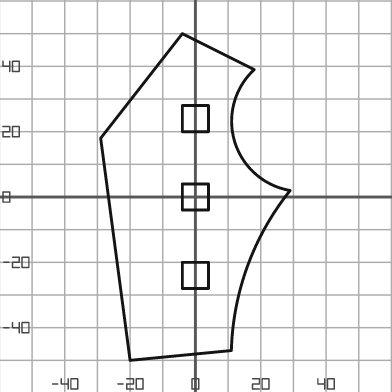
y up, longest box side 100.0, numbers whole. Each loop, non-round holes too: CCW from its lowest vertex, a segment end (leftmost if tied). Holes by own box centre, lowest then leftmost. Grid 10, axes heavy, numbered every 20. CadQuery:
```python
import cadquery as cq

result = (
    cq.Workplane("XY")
    .moveTo(-20.0, -50.0)
    .lineTo(11.0, -47.0)
    .threePointArc((16.0, -21.0), (29.0, 2.0))
    .threePointArc((12.0, 17.0), (18.0, 39.0))
    .lineTo(-4.0, 50.0)
    .lineTo(-29.0, 18.0)
    .close()
    .moveTo(-4.0, -28.0)
    .lineTo(4.0, -28.0)
    .lineTo(4.0, -20.0)
    .lineTo(-4.0, -20.0)
    .close()
    .moveTo(-4.0, -4.0)
    .lineTo(4.0, -4.0)
    .lineTo(4.0, 4.0)
    .lineTo(-4.0, 4.0)
    .close()
    .moveTo(-4.0, 20.0)
    .lineTo(4.0, 20.0)
    .lineTo(4.0, 28.0)
    .lineTo(-4.0, 28.0)
    .close()
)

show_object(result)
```